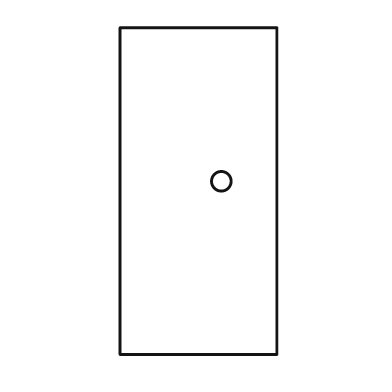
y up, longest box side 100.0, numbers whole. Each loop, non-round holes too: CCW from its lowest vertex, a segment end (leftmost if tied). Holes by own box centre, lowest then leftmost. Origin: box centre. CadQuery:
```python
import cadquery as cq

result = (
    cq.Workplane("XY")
    .moveTo(-24.0, -50.0)
    .lineTo(24.0, -50.0)
    .lineTo(24.0, 50.0)
    .lineTo(-24.0, 50.0)
    .close()
    .moveTo(7.0, 3.0)
    .circle(3.0)
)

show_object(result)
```